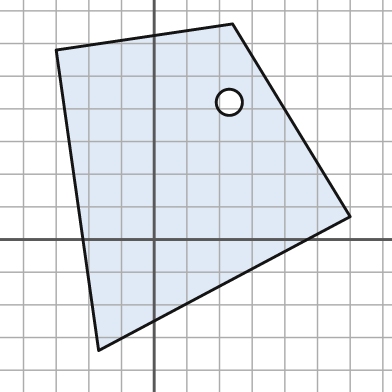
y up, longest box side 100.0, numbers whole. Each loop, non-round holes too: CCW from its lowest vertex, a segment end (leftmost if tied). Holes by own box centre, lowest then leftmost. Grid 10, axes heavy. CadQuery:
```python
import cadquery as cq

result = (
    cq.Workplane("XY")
    .moveTo(-17.0, -34.0)
    .lineTo(60.0, 7.0)
    .lineTo(24.0, 66.0)
    .lineTo(-30.0, 58.0)
    .close()
    .moveTo(23.0, 42.0)
    .circle(4.0)
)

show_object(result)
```